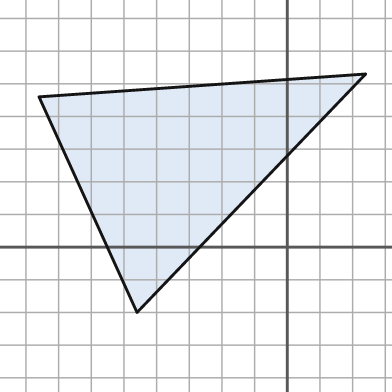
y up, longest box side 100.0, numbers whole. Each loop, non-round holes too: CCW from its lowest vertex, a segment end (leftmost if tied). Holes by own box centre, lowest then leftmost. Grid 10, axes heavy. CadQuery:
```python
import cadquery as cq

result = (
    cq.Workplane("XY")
    .moveTo(-46.0, -20.0)
    .lineTo(24.0, 53.0)
    .lineTo(-76.0, 46.0)
    .close()
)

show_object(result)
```